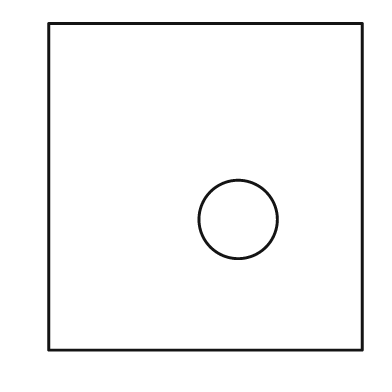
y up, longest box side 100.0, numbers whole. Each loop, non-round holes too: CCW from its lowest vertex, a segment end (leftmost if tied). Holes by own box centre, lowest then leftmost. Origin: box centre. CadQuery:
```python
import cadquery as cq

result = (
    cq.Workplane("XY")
    .moveTo(-48.0, -50.0)
    .lineTo(48.0, -50.0)
    .lineTo(48.0, 50.0)
    .lineTo(-48.0, 50.0)
    .close()
    .moveTo(10.0, -10.0)
    .circle(12.0)
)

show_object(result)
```